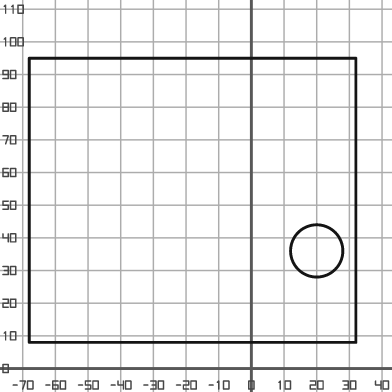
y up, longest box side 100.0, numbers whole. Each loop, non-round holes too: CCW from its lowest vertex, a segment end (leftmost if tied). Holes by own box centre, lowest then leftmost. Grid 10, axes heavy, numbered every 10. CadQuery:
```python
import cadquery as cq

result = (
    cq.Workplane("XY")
    .moveTo(-68.0, 8.0)
    .lineTo(32.0, 8.0)
    .lineTo(32.0, 95.0)
    .lineTo(-68.0, 95.0)
    .close()
    .moveTo(20.0, 36.0)
    .circle(8.0)
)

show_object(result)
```